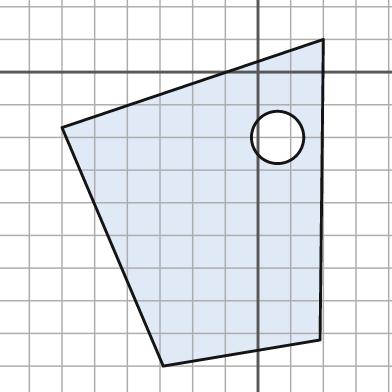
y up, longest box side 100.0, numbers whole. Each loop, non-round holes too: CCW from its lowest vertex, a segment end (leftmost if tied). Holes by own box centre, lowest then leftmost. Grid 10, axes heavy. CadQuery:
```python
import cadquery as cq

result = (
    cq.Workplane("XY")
    .moveTo(-29.0, -90.0)
    .lineTo(19.0, -82.0)
    .lineTo(20.0, 10.0)
    .lineTo(-60.0, -17.0)
    .close()
    .moveTo(6.0, -20.0)
    .circle(8.0)
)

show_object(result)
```